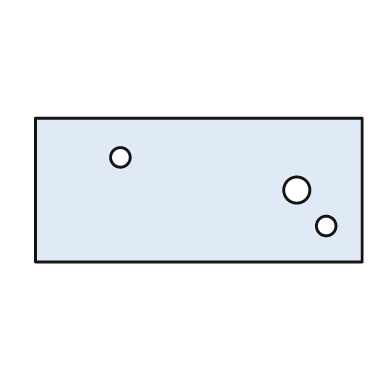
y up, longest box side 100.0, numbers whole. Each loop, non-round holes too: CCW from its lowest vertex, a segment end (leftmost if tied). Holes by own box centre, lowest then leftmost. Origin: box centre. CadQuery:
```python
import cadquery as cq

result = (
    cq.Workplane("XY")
    .moveTo(-50.0, -22.0)
    .lineTo(50.0, -22.0)
    .lineTo(50.0, 22.0)
    .lineTo(-50.0, 22.0)
    .close()
    .moveTo(39.0, -11.0)
    .circle(3.0)
    .moveTo(30.0, 0.0)
    .circle(4.0)
    .moveTo(-24.0, 10.0)
    .circle(3.0)
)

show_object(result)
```